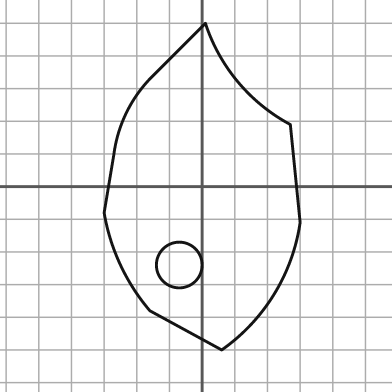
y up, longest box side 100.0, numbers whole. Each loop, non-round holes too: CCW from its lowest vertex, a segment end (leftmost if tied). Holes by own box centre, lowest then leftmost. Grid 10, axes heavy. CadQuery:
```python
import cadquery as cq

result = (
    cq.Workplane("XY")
    .moveTo(6.0, -50.0)
    .threePointArc((22.0, -33.0), (30.0, -11.0))
    .lineTo(27.0, 19.0)
    .threePointArc((11.0, 32.0), (1.0, 50.0))
    .lineTo(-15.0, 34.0)
    .threePointArc((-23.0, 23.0), (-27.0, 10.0))
    .lineTo(-30.0, -8.0)
    .threePointArc((-25.0, -24.0), (-16.0, -38.0))
    .close()
    .moveTo(-7.0, -24.0)
    .circle(7.0)
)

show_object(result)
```